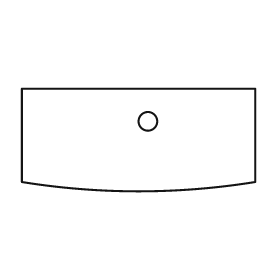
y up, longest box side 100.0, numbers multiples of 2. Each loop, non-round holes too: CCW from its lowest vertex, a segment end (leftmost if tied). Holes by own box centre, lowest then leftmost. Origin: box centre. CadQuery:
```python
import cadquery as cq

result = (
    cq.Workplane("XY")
    .moveTo(-50.0, -18.0)
    .threePointArc((0.0, -22.0), (50.0, -18.0))
    .lineTo(50.0, 22.0)
    .lineTo(-50.0, 22.0)
    .close()
    .moveTo(4.0, 8.0)
    .circle(4.0)
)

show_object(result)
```